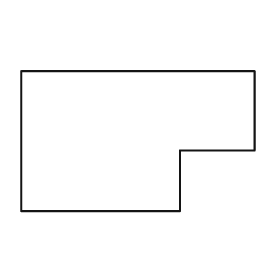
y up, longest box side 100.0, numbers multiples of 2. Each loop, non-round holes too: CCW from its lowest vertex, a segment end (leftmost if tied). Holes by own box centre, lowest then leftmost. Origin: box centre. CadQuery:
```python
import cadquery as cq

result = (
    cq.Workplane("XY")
    .moveTo(-50.0, -30.0)
    .lineTo(18.0, -30.0)
    .lineTo(18.0, -4.0)
    .lineTo(50.0, -4.0)
    .lineTo(50.0, 30.0)
    .lineTo(-50.0, 30.0)
    .close()
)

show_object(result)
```